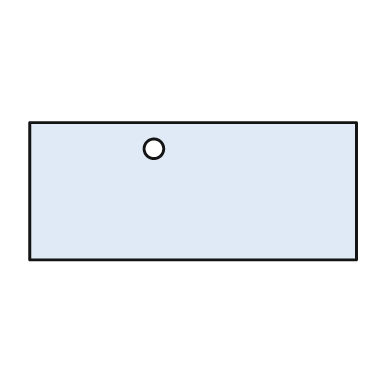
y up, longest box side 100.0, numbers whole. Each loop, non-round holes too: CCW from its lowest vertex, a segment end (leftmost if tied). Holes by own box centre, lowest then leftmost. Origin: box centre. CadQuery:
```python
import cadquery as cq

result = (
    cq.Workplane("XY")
    .moveTo(-50.0, -21.0)
    .lineTo(50.0, -21.0)
    .lineTo(50.0, 21.0)
    .lineTo(-50.0, 21.0)
    .close()
    .moveTo(-12.0, 13.0)
    .circle(3.0)
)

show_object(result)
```